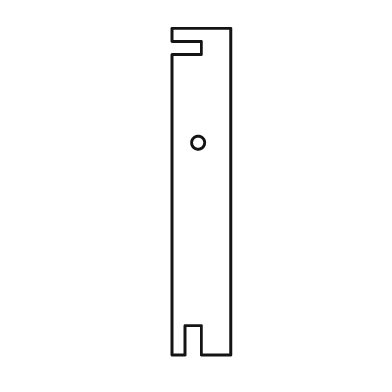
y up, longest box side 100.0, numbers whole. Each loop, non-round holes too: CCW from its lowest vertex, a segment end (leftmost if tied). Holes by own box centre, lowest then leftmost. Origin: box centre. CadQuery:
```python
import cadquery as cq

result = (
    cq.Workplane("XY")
    .moveTo(-9.0, -50.0)
    .lineTo(-5.0, -50.0)
    .lineTo(-5.0, -41.0)
    .lineTo(0.0, -41.0)
    .lineTo(0.0, -50.0)
    .lineTo(9.0, -50.0)
    .lineTo(9.0, 50.0)
    .lineTo(-9.0, 50.0)
    .lineTo(-9.0, 46.0)
    .lineTo(0.0, 46.0)
    .lineTo(0.0, 42.0)
    .lineTo(-9.0, 42.0)
    .close()
    .moveTo(-1.0, 15.0)
    .circle(2.0)
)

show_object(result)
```